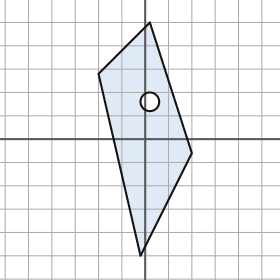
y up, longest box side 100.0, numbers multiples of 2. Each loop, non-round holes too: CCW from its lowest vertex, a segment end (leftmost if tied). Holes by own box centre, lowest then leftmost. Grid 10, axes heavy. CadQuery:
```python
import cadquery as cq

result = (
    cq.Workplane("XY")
    .moveTo(-2.0, -50.0)
    .lineTo(20.0, -6.0)
    .lineTo(2.0, 50.0)
    .lineTo(-20.0, 28.0)
    .close()
    .moveTo(2.0, 16.0)
    .circle(4.0)
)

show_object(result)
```